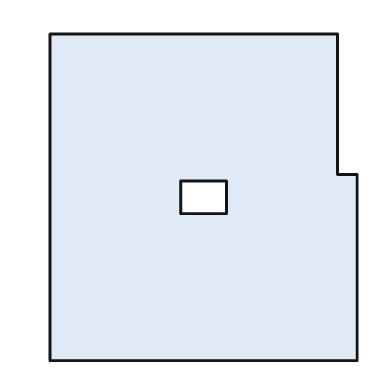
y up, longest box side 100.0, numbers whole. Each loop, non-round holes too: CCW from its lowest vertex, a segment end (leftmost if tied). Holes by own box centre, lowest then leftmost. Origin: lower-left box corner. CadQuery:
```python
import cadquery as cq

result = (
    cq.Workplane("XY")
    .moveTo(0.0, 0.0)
    .lineTo(94.0, 0.0)
    .lineTo(94.0, 57.0)
    .lineTo(88.0, 57.0)
    .lineTo(88.0, 100.0)
    .lineTo(0.0, 100.0)
    .close()
    .moveTo(40.0, 45.0)
    .lineTo(54.0, 45.0)
    .lineTo(54.0, 55.0)
    .lineTo(40.0, 55.0)
    .close()
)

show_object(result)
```